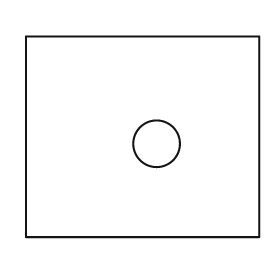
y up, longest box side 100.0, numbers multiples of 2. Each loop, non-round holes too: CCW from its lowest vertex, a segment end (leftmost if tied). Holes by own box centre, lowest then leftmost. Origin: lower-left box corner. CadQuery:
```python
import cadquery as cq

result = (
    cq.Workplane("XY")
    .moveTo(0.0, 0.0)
    .lineTo(100.0, 0.0)
    .lineTo(100.0, 86.0)
    .lineTo(0.0, 86.0)
    .close()
    .moveTo(56.0, 40.0)
    .circle(10.0)
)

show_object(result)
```